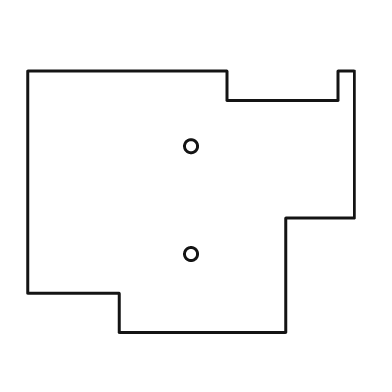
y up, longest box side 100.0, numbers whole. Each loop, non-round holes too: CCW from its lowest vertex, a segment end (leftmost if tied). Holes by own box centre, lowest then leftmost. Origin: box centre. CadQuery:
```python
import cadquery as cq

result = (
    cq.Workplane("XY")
    .moveTo(-22.0, -40.0)
    .lineTo(29.0, -40.0)
    .lineTo(29.0, -5.0)
    .lineTo(50.0, -5.0)
    .lineTo(50.0, 40.0)
    .lineTo(45.0, 40.0)
    .lineTo(45.0, 31.0)
    .lineTo(11.0, 31.0)
    .lineTo(11.0, 40.0)
    .lineTo(-50.0, 40.0)
    .lineTo(-50.0, -28.0)
    .lineTo(-22.0, -28.0)
    .close()
    .moveTo(0.0, -16.0)
    .circle(2.0)
    .moveTo(0.0, 17.0)
    .circle(2.0)
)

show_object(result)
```